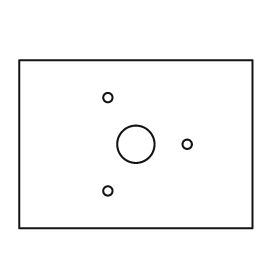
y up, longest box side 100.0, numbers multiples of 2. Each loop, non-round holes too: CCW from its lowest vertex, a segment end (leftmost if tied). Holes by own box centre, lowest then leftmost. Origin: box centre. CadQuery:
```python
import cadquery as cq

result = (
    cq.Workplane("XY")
    .moveTo(-50.0, -36.0)
    .lineTo(50.0, -36.0)
    .lineTo(50.0, 36.0)
    .lineTo(-50.0, 36.0)
    .close()
    .moveTo(-12.0, -20.0)
    .circle(2.0)
    .moveTo(0.0, 0.0)
    .circle(8.0)
    .moveTo(22.0, 0.0)
    .circle(2.0)
    .moveTo(-12.0, 20.0)
    .circle(2.0)
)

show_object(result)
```